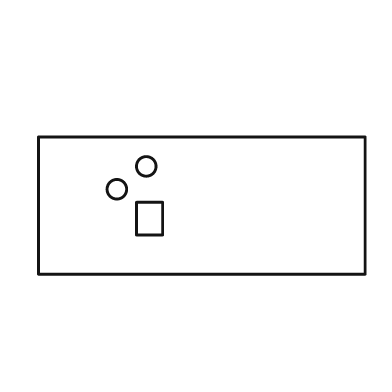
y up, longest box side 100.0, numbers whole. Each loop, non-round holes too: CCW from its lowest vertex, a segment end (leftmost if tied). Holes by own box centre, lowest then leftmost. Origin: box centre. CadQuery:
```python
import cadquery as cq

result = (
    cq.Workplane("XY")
    .moveTo(-50.0, -21.0)
    .lineTo(50.0, -21.0)
    .lineTo(50.0, 21.0)
    .lineTo(-50.0, 21.0)
    .close()
    .moveTo(-20.0, -9.0)
    .lineTo(-12.0, -9.0)
    .lineTo(-12.0, 1.0)
    .lineTo(-20.0, 1.0)
    .close()
    .moveTo(-26.0, 5.0)
    .circle(3.0)
    .moveTo(-17.0, 12.0)
    .circle(3.0)
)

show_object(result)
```